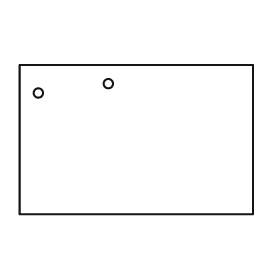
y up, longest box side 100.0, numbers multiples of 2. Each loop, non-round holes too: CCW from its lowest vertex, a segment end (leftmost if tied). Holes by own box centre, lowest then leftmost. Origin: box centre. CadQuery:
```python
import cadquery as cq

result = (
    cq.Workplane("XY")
    .moveTo(-50.0, -32.0)
    .lineTo(50.0, -32.0)
    .lineTo(50.0, 32.0)
    .lineTo(-50.0, 32.0)
    .close()
    .moveTo(-42.0, 20.0)
    .circle(2.0)
    .moveTo(-12.0, 24.0)
    .circle(2.0)
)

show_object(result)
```